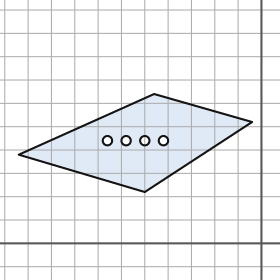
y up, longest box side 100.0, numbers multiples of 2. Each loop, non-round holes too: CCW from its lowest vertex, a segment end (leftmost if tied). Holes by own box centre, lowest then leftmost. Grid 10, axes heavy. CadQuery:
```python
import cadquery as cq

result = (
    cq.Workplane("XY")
    .moveTo(-50.0, 22.0)
    .lineTo(-4.0, 52.0)
    .lineTo(-46.0, 64.0)
    .lineTo(-104.0, 38.0)
    .close()
    .moveTo(-66.0, 44.0)
    .circle(2.0)
    .moveTo(-58.0, 44.0)
    .circle(2.0)
    .moveTo(-50.0, 44.0)
    .circle(2.0)
    .moveTo(-42.0, 44.0)
    .circle(2.0)
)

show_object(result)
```